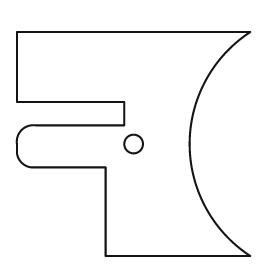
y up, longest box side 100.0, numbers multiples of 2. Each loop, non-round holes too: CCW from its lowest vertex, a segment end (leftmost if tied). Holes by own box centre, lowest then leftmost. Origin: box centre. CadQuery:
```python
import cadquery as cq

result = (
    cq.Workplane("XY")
    .moveTo(-12.0, -48.0)
    .lineTo(50.0, -48.0)
    .threePointArc((24.0, 0.0), (50.0, 48.0))
    .lineTo(-50.0, 48.0)
    .lineTo(-50.0, 18.0)
    .lineTo(-4.0, 18.0)
    .lineTo(-4.0, 8.0)
    .lineTo(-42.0, 8.0)
    .threePointArc((-48.0, 6.0), (-50.0, 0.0))
    .lineTo(-50.0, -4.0)
    .threePointArc((-48.0, -8.0), (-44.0, -10.0))
    .lineTo(-12.0, -10.0)
    .close()
    .moveTo(0.0, 0.0)
    .circle(4.0)
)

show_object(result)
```